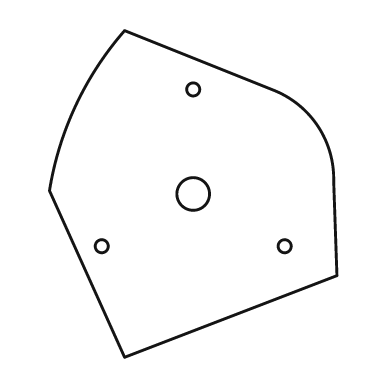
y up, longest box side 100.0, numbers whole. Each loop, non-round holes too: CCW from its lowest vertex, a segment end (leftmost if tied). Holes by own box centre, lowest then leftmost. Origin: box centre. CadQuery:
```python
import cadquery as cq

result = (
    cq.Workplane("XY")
    .moveTo(-21.0, -50.0)
    .lineTo(44.0, -25.0)
    .lineTo(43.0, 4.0)
    .threePointArc((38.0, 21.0), (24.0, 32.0))
    .lineTo(-21.0, 50.0)
    .threePointArc((-36.0, 27.0), (-44.0, 1.0))
    .close()
    .moveTo(-28.0, -16.0)
    .circle(2.0)
    .moveTo(28.0, -16.0)
    .circle(2.0)
    .moveTo(0.0, 0.0)
    .circle(5.0)
    .moveTo(0.0, 32.0)
    .circle(2.0)
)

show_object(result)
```